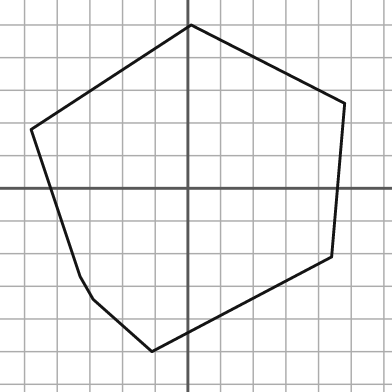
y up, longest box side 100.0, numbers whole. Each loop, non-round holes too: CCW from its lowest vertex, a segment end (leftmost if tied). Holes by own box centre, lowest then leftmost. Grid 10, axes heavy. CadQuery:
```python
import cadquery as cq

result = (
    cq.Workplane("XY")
    .moveTo(-11.0, -50.0)
    .lineTo(44.0, -21.0)
    .lineTo(48.0, 26.0)
    .lineTo(1.0, 50.0)
    .lineTo(-48.0, 18.0)
    .lineTo(-33.0, -27.0)
    .lineTo(-29.0, -34.0)
    .close()
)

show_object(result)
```